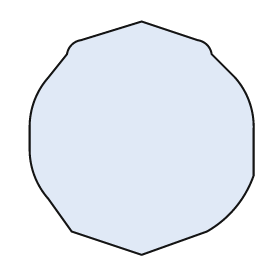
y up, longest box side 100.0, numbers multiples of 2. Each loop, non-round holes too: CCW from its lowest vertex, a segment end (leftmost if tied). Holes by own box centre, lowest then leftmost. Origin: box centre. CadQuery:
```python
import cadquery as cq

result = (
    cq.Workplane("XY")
    .moveTo(0.0, -50.0)
    .lineTo(28.0, -40.0)
    .threePointArc((40.0, -30.0), (48.0, -16.0))
    .lineTo(48.0, 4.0)
    .threePointArc((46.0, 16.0), (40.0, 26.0))
    .lineTo(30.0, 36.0)
    .threePointArc((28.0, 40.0), (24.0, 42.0))
    .lineTo(0.0, 50.0)
    .lineTo(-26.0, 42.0)
    .threePointArc((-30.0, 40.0), (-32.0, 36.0))
    .lineTo(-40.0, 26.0)
    .threePointArc((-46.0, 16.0), (-48.0, 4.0))
    .lineTo(-48.0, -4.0)
    .threePointArc((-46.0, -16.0), (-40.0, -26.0))
    .lineTo(-30.0, -40.0)
    .close()
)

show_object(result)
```